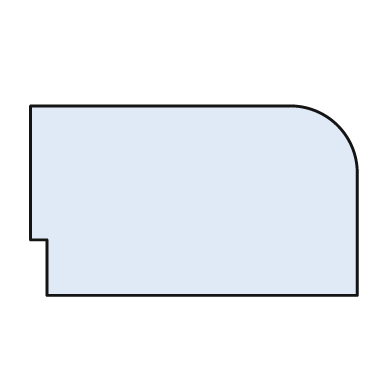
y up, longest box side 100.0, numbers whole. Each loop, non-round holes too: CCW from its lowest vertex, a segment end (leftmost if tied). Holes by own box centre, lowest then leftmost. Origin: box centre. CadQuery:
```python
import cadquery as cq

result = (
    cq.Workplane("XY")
    .moveTo(-45.0, -29.0)
    .lineTo(50.0, -29.0)
    .lineTo(50.0, 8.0)
    .threePointArc((44.0, 23.0), (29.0, 29.0))
    .lineTo(-50.0, 29.0)
    .lineTo(-50.0, -12.0)
    .lineTo(-45.0, -12.0)
    .close()
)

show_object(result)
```